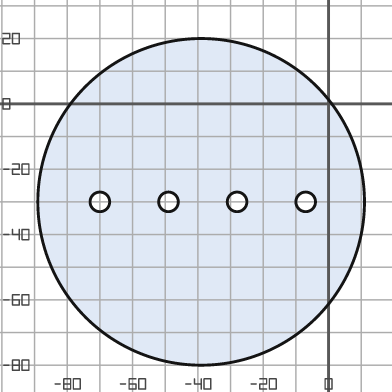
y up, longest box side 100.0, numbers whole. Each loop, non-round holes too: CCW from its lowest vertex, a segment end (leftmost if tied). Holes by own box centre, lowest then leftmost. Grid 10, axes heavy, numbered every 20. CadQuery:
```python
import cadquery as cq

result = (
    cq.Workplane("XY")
    .moveTo(-39.0, -30.0)
    .circle(50.0)
    .moveTo(-70.0, -30.0)
    .circle(3.0)
    .moveTo(-49.0, -30.0)
    .circle(3.0)
    .moveTo(-28.0, -30.0)
    .circle(3.0)
    .moveTo(-7.0, -30.0)
    .circle(3.0)
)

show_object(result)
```